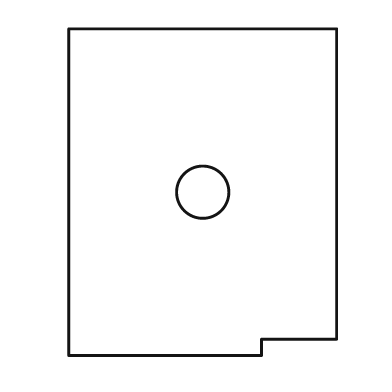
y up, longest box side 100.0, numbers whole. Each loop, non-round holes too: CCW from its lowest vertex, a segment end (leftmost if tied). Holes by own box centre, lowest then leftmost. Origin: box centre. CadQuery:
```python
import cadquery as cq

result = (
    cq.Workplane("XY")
    .moveTo(-41.0, -50.0)
    .lineTo(18.0, -50.0)
    .lineTo(18.0, -45.0)
    .lineTo(41.0, -45.0)
    .lineTo(41.0, 50.0)
    .lineTo(-41.0, 50.0)
    .close()
    .moveTo(0.0, 0.0)
    .circle(8.0)
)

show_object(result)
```